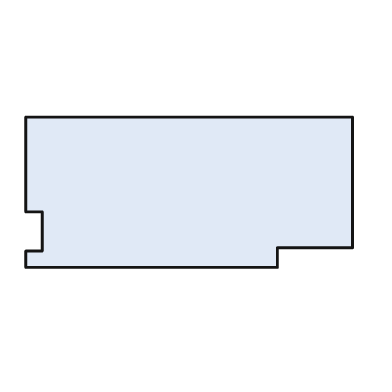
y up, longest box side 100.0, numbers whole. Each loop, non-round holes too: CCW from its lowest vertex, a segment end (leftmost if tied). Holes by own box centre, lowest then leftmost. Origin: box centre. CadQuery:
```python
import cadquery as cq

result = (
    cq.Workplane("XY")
    .moveTo(-50.0, -23.0)
    .lineTo(27.0, -23.0)
    .lineTo(27.0, -17.0)
    .lineTo(50.0, -17.0)
    .lineTo(50.0, 23.0)
    .lineTo(-50.0, 23.0)
    .lineTo(-50.0, -6.0)
    .lineTo(-45.0, -6.0)
    .lineTo(-45.0, -18.0)
    .lineTo(-50.0, -18.0)
    .close()
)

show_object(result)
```